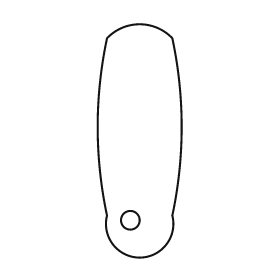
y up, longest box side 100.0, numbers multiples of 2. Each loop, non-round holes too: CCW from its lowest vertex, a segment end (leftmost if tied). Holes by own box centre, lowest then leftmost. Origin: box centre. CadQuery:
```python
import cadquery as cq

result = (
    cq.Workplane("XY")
    .moveTo(-14.0, -32.0)
    .threePointArc((0.0, -50.0), (14.0, -32.0))
    .threePointArc((18.0, 6.0), (14.0, 44.0))
    .threePointArc((0.0, 50.0), (-14.0, 44.0))
    .threePointArc((-18.0, 6.0), (-14.0, -32.0))
    .close()
    .moveTo(-4.0, -34.0)
    .circle(4.0)
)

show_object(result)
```